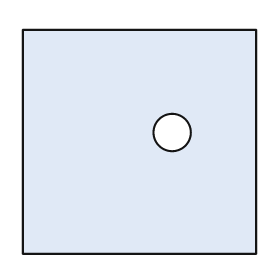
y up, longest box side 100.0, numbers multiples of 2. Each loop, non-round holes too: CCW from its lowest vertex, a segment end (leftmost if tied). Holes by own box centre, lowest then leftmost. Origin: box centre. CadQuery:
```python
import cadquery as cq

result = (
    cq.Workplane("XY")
    .moveTo(-50.0, -48.0)
    .lineTo(50.0, -48.0)
    .lineTo(50.0, 48.0)
    .lineTo(-50.0, 48.0)
    .close()
    .moveTo(14.0, 4.0)
    .circle(8.0)
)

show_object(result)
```